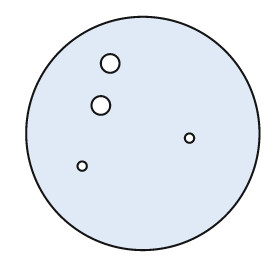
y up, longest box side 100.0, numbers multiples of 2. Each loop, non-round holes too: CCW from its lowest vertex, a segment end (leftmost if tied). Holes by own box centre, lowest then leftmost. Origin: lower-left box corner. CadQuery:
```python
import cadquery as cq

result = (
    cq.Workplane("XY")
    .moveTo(50.0, 50.0)
    .circle(50.0)
    .moveTo(24.0, 36.0)
    .circle(2.0)
    .moveTo(70.0, 48.0)
    .circle(2.0)
    .moveTo(32.0, 62.0)
    .circle(4.0)
    .moveTo(36.0, 80.0)
    .circle(4.0)
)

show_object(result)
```